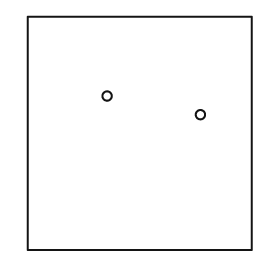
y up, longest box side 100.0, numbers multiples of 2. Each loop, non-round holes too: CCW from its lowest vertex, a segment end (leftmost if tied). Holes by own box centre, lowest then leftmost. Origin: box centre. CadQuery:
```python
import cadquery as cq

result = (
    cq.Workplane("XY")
    .moveTo(-48.0, -50.0)
    .lineTo(48.0, -50.0)
    .lineTo(48.0, 50.0)
    .lineTo(-48.0, 50.0)
    .close()
    .moveTo(26.0, 8.0)
    .circle(2.0)
    .moveTo(-14.0, 16.0)
    .circle(2.0)
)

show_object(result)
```